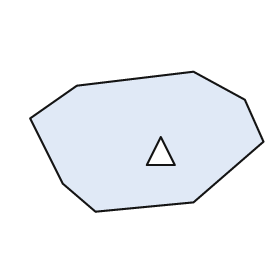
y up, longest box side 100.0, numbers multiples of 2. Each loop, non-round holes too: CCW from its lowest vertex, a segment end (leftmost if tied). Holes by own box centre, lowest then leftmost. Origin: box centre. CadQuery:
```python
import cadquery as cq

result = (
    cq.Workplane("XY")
    .moveTo(-22.0, -30.0)
    .lineTo(20.0, -26.0)
    .lineTo(50.0, 0.0)
    .lineTo(42.0, 18.0)
    .lineTo(20.0, 30.0)
    .lineTo(-30.0, 24.0)
    .lineTo(-50.0, 10.0)
    .lineTo(-36.0, -18.0)
    .close()
    .moveTo(0.0, -10.0)
    .lineTo(12.0, -10.0)
    .lineTo(6.0, 2.0)
    .close()
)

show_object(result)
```